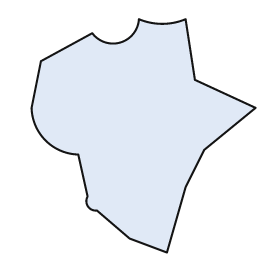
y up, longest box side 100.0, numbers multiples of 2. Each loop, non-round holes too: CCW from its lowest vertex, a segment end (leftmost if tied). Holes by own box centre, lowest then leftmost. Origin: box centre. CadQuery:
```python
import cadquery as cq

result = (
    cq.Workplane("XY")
    .moveTo(10.0, -50.0)
    .lineTo(18.0, -22.0)
    .lineTo(26.0, -6.0)
    .lineTo(48.0, 12.0)
    .lineTo(22.0, 24.0)
    .lineTo(18.0, 50.0)
    .threePointArc((8.0, 48.0), (-2.0, 50.0))
    .threePointArc((-10.0, 40.0), (-22.0, 44.0))
    .lineTo(-44.0, 32.0)
    .lineTo(-48.0, 12.0)
    .threePointArc((-42.0, -2.0), (-28.0, -8.0))
    .lineTo(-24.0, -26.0)
    .threePointArc((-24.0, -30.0), (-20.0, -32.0))
    .lineTo(-6.0, -44.0)
    .close()
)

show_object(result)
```